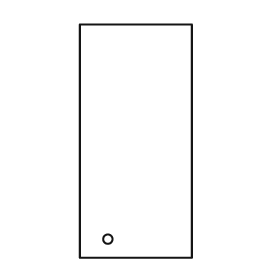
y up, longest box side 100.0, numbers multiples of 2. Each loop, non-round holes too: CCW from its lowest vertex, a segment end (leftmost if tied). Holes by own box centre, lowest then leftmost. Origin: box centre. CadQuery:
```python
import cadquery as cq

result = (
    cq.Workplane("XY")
    .moveTo(-24.0, -50.0)
    .lineTo(24.0, -50.0)
    .lineTo(24.0, 50.0)
    .lineTo(-24.0, 50.0)
    .close()
    .moveTo(-12.0, -42.0)
    .circle(2.0)
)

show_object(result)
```